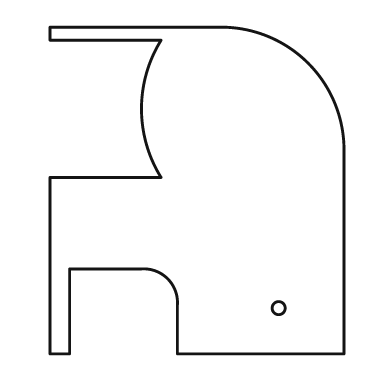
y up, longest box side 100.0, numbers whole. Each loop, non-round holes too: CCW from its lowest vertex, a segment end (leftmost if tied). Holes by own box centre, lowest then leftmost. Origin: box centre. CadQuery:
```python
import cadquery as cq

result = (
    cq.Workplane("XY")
    .moveTo(-45.0, -50.0)
    .lineTo(-39.0, -50.0)
    .lineTo(-39.0, -24.0)
    .lineTo(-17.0, -24.0)
    .threePointArc((-9.0, -27.0), (-6.0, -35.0))
    .lineTo(-6.0, -50.0)
    .lineTo(45.0, -50.0)
    .lineTo(45.0, 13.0)
    .threePointArc((34.0, 39.0), (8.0, 50.0))
    .lineTo(-45.0, 50.0)
    .lineTo(-45.0, 46.0)
    .lineTo(-11.0, 46.0)
    .threePointArc((-17.0, 25.0), (-11.0, 4.0))
    .lineTo(-45.0, 4.0)
    .close()
    .moveTo(25.0, -36.0)
    .circle(2.0)
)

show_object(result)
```